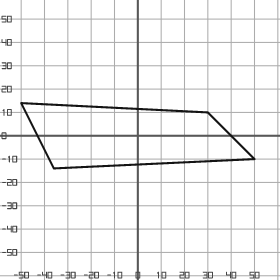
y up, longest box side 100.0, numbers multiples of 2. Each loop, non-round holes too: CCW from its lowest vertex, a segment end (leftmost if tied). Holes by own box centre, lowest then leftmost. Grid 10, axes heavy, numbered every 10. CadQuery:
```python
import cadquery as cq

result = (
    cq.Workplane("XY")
    .moveTo(-36.0, -14.0)
    .lineTo(50.0, -10.0)
    .lineTo(30.0, 10.0)
    .lineTo(-50.0, 14.0)
    .close()
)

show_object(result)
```